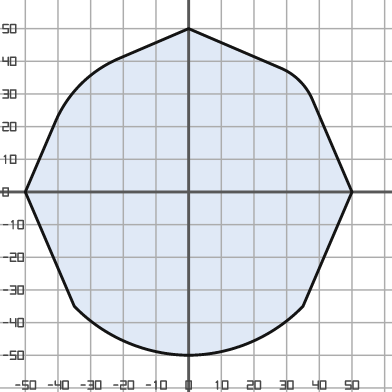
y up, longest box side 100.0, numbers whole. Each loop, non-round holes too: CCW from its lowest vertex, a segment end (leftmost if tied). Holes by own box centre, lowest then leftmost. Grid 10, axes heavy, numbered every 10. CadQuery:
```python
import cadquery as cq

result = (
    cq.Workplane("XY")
    .moveTo(0.0, -50.0)
    .threePointArc((19.0, -46.0), (35.0, -35.0))
    .lineTo(50.0, 0.0)
    .lineTo(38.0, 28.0)
    .threePointArc((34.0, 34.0), (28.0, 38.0))
    .lineTo(0.0, 50.0)
    .lineTo(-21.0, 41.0)
    .threePointArc((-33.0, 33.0), (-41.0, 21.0))
    .lineTo(-50.0, 0.0)
    .lineTo(-35.0, -35.0)
    .threePointArc((-19.0, -46.0), (0.0, -50.0))
    .close()
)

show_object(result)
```